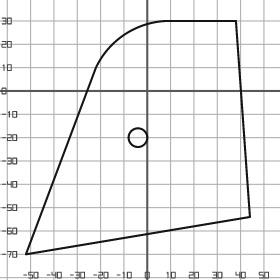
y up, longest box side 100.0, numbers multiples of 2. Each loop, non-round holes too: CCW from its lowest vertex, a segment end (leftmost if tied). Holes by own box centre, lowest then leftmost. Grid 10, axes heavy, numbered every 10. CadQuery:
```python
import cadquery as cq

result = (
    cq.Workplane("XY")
    .moveTo(-52.0, -70.0)
    .lineTo(44.0, -54.0)
    .lineTo(38.0, 30.0)
    .lineTo(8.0, 30.0)
    .threePointArc((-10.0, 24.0), (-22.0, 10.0))
    .close()
    .moveTo(-4.0, -20.0)
    .circle(4.0)
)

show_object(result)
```